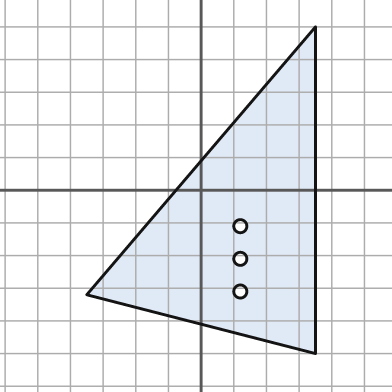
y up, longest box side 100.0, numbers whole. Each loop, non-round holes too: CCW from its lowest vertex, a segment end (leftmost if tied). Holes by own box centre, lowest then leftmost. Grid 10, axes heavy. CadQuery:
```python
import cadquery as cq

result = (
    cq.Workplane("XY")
    .moveTo(35.0, -50.0)
    .lineTo(35.0, 50.0)
    .lineTo(-35.0, -32.0)
    .close()
    .moveTo(12.0, -31.0)
    .circle(2.0)
    .moveTo(12.0, -21.0)
    .circle(2.0)
    .moveTo(12.0, -11.0)
    .circle(2.0)
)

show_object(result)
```